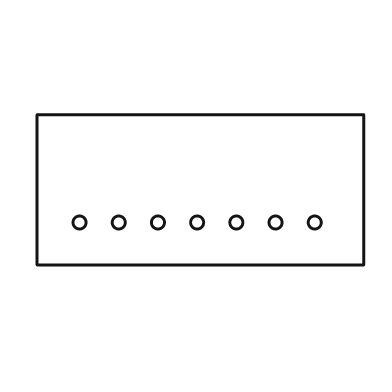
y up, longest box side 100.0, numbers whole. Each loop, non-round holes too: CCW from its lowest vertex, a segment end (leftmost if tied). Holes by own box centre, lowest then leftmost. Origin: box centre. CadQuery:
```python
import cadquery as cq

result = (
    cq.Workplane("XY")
    .moveTo(-50.0, -23.0)
    .lineTo(50.0, -23.0)
    .lineTo(50.0, 23.0)
    .lineTo(-50.0, 23.0)
    .close()
    .moveTo(-37.0, -10.0)
    .circle(2.0)
    .moveTo(-25.0, -10.0)
    .circle(2.0)
    .moveTo(-13.0, -10.0)
    .circle(2.0)
    .moveTo(-1.0, -10.0)
    .circle(2.0)
    .moveTo(11.0, -10.0)
    .circle(2.0)
    .moveTo(23.0, -10.0)
    .circle(2.0)
    .moveTo(35.0, -10.0)
    .circle(2.0)
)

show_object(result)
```